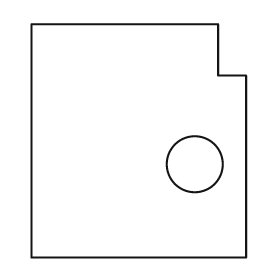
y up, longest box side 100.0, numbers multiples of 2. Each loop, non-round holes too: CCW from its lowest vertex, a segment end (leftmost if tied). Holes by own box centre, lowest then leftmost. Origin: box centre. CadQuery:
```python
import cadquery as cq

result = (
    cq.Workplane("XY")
    .moveTo(-46.0, -50.0)
    .lineTo(46.0, -50.0)
    .lineTo(46.0, 28.0)
    .lineTo(34.0, 28.0)
    .lineTo(34.0, 50.0)
    .lineTo(-46.0, 50.0)
    .close()
    .moveTo(24.0, -10.0)
    .circle(12.0)
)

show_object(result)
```